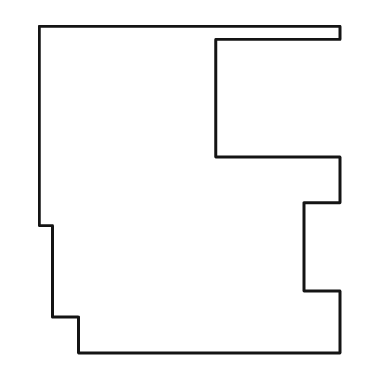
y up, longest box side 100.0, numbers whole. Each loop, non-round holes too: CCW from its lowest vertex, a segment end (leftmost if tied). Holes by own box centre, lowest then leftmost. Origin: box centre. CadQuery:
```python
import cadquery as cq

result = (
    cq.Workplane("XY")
    .moveTo(-34.0, -50.0)
    .lineTo(46.0, -50.0)
    .lineTo(46.0, -31.0)
    .lineTo(35.0, -31.0)
    .lineTo(35.0, -4.0)
    .lineTo(46.0, -4.0)
    .lineTo(46.0, 10.0)
    .lineTo(8.0, 10.0)
    .lineTo(8.0, 46.0)
    .lineTo(46.0, 46.0)
    .lineTo(46.0, 50.0)
    .lineTo(-46.0, 50.0)
    .lineTo(-46.0, -11.0)
    .lineTo(-42.0, -11.0)
    .lineTo(-42.0, -39.0)
    .lineTo(-34.0, -39.0)
    .close()
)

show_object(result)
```